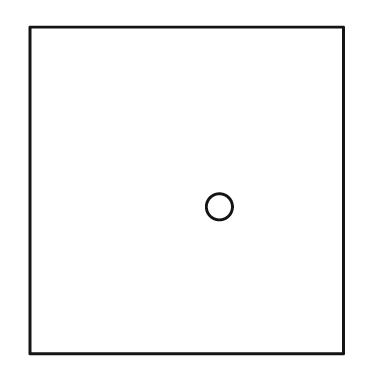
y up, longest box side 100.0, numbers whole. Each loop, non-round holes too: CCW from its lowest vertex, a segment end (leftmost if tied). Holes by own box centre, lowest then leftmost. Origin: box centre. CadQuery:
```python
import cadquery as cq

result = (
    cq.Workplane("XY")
    .moveTo(-48.0, -50.0)
    .lineTo(48.0, -50.0)
    .lineTo(48.0, 50.0)
    .lineTo(-48.0, 50.0)
    .close()
    .moveTo(10.0, -5.0)
    .circle(4.0)
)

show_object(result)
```